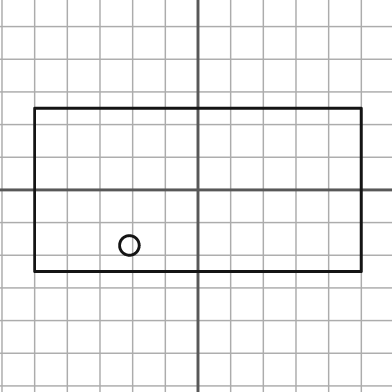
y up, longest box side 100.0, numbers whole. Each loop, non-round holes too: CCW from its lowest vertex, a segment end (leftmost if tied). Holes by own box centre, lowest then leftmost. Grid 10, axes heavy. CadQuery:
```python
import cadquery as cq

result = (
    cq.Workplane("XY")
    .moveTo(-50.0, -25.0)
    .lineTo(50.0, -25.0)
    .lineTo(50.0, 25.0)
    .lineTo(-50.0, 25.0)
    .close()
    .moveTo(-21.0, -17.0)
    .circle(3.0)
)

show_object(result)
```